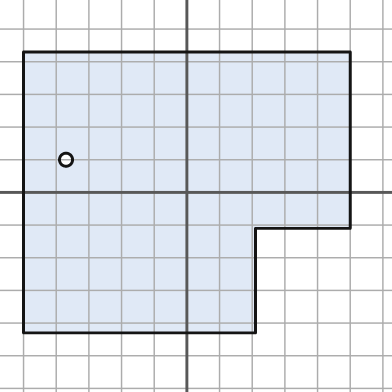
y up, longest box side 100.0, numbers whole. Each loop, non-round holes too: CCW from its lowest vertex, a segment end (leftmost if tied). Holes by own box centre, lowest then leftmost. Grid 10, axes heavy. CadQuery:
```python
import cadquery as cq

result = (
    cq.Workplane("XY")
    .moveTo(-50.0, -43.0)
    .lineTo(21.0, -43.0)
    .lineTo(21.0, -11.0)
    .lineTo(50.0, -11.0)
    .lineTo(50.0, 43.0)
    .lineTo(-50.0, 43.0)
    .close()
    .moveTo(-37.0, 10.0)
    .circle(2.0)
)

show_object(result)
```